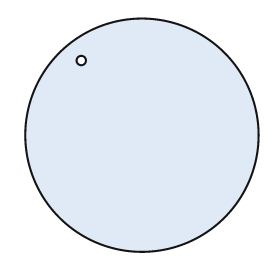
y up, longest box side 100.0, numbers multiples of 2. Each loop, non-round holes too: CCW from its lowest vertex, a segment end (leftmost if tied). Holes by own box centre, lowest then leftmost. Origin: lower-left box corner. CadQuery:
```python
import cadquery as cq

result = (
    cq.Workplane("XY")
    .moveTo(50.0, 50.0)
    .circle(50.0)
    .moveTo(24.0, 82.0)
    .circle(2.0)
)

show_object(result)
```